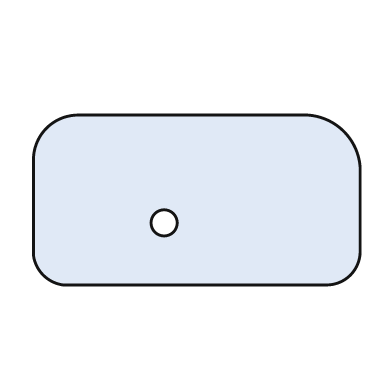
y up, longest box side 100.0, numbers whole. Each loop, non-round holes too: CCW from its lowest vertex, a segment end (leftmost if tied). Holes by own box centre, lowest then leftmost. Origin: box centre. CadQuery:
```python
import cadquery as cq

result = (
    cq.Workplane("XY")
    .moveTo(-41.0, -26.0)
    .lineTo(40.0, -26.0)
    .threePointArc((47.0, -23.0), (50.0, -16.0))
    .lineTo(50.0, 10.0)
    .threePointArc((45.0, 21.0), (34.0, 26.0))
    .lineTo(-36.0, 26.0)
    .threePointArc((-46.0, 22.0), (-50.0, 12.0))
    .lineTo(-50.0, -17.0)
    .threePointArc((-47.0, -23.0), (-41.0, -26.0))
    .close()
    .moveTo(-10.0, -7.0)
    .circle(4.0)
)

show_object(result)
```